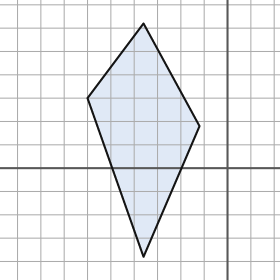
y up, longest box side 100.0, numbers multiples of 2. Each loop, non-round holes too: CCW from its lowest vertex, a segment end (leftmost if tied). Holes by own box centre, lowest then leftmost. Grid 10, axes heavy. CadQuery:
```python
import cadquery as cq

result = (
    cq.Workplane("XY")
    .moveTo(-36.0, -38.0)
    .lineTo(-12.0, 18.0)
    .lineTo(-36.0, 62.0)
    .lineTo(-60.0, 30.0)
    .close()
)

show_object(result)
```